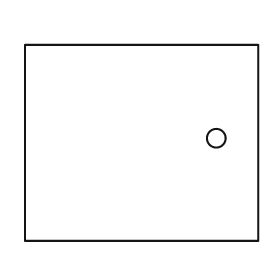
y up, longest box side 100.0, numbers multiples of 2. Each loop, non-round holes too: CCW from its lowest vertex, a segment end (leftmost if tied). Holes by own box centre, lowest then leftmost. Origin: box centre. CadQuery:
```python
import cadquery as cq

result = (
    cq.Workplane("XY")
    .moveTo(-50.0, -42.0)
    .lineTo(50.0, -42.0)
    .lineTo(50.0, 42.0)
    .lineTo(-50.0, 42.0)
    .close()
    .moveTo(32.0, 2.0)
    .circle(4.0)
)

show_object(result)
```